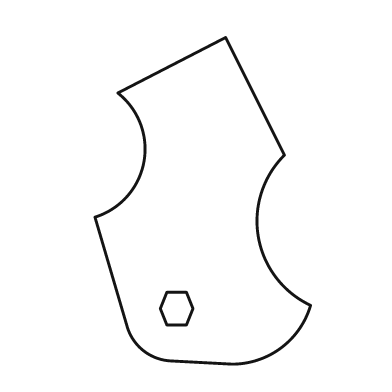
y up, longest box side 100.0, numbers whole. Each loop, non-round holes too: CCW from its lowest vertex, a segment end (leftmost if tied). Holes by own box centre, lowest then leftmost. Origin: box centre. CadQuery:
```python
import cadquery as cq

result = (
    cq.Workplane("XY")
    .moveTo(9.0, -50.0)
    .threePointArc((24.0, -45.0), (33.0, -32.0))
    .threePointArc((17.0, -11.0), (25.0, 14.0))
    .lineTo(7.0, 50.0)
    .lineTo(-26.0, 33.0)
    .threePointArc((-18.0, 12.0), (-33.0, -5.0))
    .lineTo(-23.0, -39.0)
    .threePointArc((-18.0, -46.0), (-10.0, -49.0))
    .close()
    .moveTo(-11.0, -38.0)
    .lineTo(-5.0, -38.0)
    .lineTo(-3.0, -33.0)
    .lineTo(-5.0, -28.0)
    .lineTo(-11.0, -28.0)
    .lineTo(-13.0, -33.0)
    .close()
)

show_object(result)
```